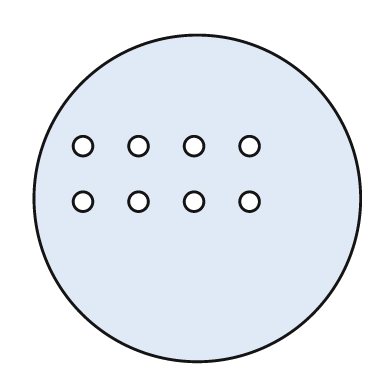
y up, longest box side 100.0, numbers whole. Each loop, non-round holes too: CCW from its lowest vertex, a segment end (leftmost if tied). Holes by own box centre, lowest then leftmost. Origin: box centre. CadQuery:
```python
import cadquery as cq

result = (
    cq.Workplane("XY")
    .moveTo(0.0, 0.0)
    .circle(50.0)
    .moveTo(-35.0, -1.0)
    .circle(3.0)
    .moveTo(-18.0, -1.0)
    .circle(3.0)
    .moveTo(-1.0, -1.0)
    .circle(3.0)
    .moveTo(16.0, -1.0)
    .circle(3.0)
    .moveTo(-35.0, 16.0)
    .circle(3.0)
    .moveTo(-18.0, 16.0)
    .circle(3.0)
    .moveTo(-1.0, 16.0)
    .circle(3.0)
    .moveTo(16.0, 16.0)
    .circle(3.0)
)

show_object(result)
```